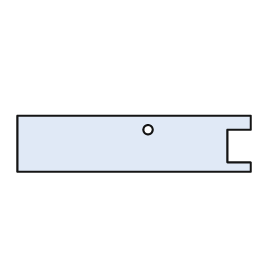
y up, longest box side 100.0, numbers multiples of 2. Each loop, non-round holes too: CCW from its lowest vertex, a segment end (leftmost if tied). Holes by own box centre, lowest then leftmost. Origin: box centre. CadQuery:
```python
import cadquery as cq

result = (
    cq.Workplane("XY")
    .moveTo(-50.0, -12.0)
    .lineTo(50.0, -12.0)
    .lineTo(50.0, -8.0)
    .lineTo(40.0, -8.0)
    .lineTo(40.0, 6.0)
    .lineTo(50.0, 6.0)
    .lineTo(50.0, 12.0)
    .lineTo(-50.0, 12.0)
    .close()
    .moveTo(6.0, 6.0)
    .circle(2.0)
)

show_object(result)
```